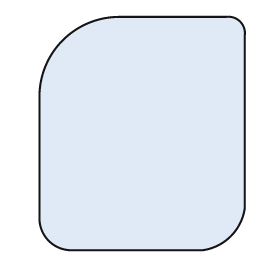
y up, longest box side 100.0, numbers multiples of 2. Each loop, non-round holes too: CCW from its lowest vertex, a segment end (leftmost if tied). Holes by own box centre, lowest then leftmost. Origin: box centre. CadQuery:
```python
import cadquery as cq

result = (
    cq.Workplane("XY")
    .moveTo(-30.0, -50.0)
    .lineTo(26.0, -50.0)
    .threePointArc((38.0, -44.0), (44.0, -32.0))
    .lineTo(44.0, 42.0)
    .threePointArc((42.0, 48.0), (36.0, 50.0))
    .lineTo(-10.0, 50.0)
    .threePointArc((-34.0, 40.0), (-44.0, 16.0))
    .lineTo(-44.0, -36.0)
    .threePointArc((-40.0, -46.0), (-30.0, -50.0))
    .close()
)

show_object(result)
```